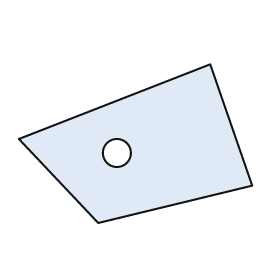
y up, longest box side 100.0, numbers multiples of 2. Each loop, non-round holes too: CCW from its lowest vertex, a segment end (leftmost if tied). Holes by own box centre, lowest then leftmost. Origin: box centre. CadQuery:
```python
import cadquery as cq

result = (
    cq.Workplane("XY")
    .moveTo(-16.0, -34.0)
    .lineTo(50.0, -18.0)
    .lineTo(32.0, 34.0)
    .lineTo(-50.0, 2.0)
    .close()
    .moveTo(-8.0, -4.0)
    .circle(6.0)
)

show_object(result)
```